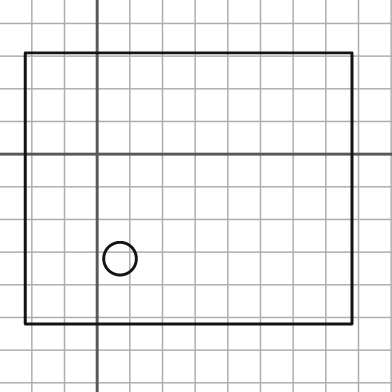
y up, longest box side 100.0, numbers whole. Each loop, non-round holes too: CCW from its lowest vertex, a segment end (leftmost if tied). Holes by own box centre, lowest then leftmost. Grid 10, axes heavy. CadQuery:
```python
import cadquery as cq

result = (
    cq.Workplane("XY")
    .moveTo(-22.0, -52.0)
    .lineTo(78.0, -52.0)
    .lineTo(78.0, 31.0)
    .lineTo(-22.0, 31.0)
    .close()
    .moveTo(7.0, -32.0)
    .circle(5.0)
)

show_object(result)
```